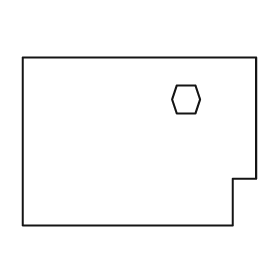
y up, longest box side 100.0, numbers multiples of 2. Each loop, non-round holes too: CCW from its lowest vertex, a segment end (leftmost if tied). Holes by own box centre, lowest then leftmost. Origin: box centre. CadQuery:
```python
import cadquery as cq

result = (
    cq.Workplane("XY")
    .moveTo(-50.0, -36.0)
    .lineTo(40.0, -36.0)
    .lineTo(40.0, -16.0)
    .lineTo(50.0, -16.0)
    .lineTo(50.0, 36.0)
    .lineTo(-50.0, 36.0)
    .close()
    .moveTo(16.0, 12.0)
    .lineTo(24.0, 12.0)
    .lineTo(26.0, 18.0)
    .lineTo(24.0, 24.0)
    .lineTo(16.0, 24.0)
    .lineTo(14.0, 18.0)
    .close()
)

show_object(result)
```